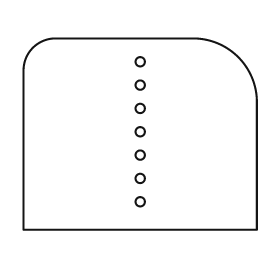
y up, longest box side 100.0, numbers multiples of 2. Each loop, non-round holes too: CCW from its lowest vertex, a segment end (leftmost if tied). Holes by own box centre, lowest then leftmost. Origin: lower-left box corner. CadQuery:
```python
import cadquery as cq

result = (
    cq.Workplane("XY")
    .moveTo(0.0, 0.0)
    .lineTo(100.0, 0.0)
    .lineTo(100.0, 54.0)
    .threePointArc((92.0, 74.0), (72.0, 82.0))
    .lineTo(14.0, 82.0)
    .threePointArc((4.0, 78.0), (0.0, 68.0))
    .close()
    .moveTo(50.0, 12.0)
    .circle(2.0)
    .moveTo(50.0, 22.0)
    .circle(2.0)
    .moveTo(50.0, 32.0)
    .circle(2.0)
    .moveTo(50.0, 42.0)
    .circle(2.0)
    .moveTo(50.0, 52.0)
    .circle(2.0)
    .moveTo(50.0, 62.0)
    .circle(2.0)
    .moveTo(50.0, 72.0)
    .circle(2.0)
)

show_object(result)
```